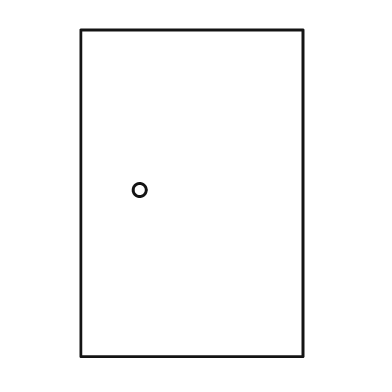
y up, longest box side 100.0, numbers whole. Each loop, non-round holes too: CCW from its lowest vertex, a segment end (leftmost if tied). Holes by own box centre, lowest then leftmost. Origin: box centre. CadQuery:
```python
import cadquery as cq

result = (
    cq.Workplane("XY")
    .moveTo(-34.0, -50.0)
    .lineTo(34.0, -50.0)
    .lineTo(34.0, 50.0)
    .lineTo(-34.0, 50.0)
    .close()
    .moveTo(-16.0, 1.0)
    .circle(2.0)
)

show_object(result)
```